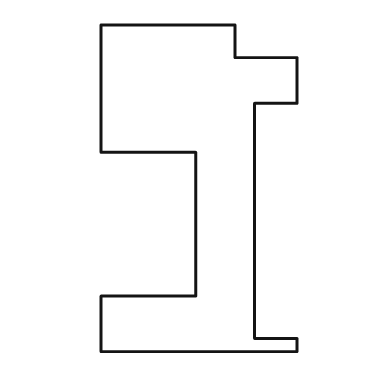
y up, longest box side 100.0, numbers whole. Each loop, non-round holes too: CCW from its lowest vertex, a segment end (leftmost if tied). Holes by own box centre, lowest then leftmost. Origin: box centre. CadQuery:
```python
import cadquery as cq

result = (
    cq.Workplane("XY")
    .moveTo(-30.0, -50.0)
    .lineTo(30.0, -50.0)
    .lineTo(30.0, -46.0)
    .lineTo(17.0, -46.0)
    .lineTo(17.0, 26.0)
    .lineTo(30.0, 26.0)
    .lineTo(30.0, 40.0)
    .lineTo(11.0, 40.0)
    .lineTo(11.0, 50.0)
    .lineTo(-30.0, 50.0)
    .lineTo(-30.0, 11.0)
    .lineTo(-1.0, 11.0)
    .lineTo(-1.0, -33.0)
    .lineTo(-30.0, -33.0)
    .close()
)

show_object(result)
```